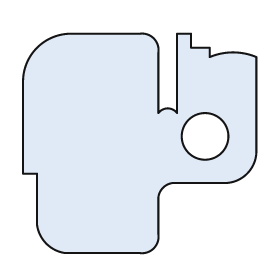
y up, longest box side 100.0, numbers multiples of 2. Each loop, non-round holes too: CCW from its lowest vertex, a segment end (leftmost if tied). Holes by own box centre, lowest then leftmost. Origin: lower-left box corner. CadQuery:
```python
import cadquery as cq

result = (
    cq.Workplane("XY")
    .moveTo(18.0, 0.0)
    .lineTo(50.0, 0.0)
    .threePointArc((56.0, 2.0), (58.0, 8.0))
    .lineTo(58.0, 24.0)
    .threePointArc((60.0, 28.0), (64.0, 30.0))
    .lineTo(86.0, 30.0)
    .threePointArc((96.0, 34.0), (100.0, 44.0))
    .lineTo(100.0, 84.0)
    .threePointArc((90.0, 86.0), (80.0, 84.0))
    .lineTo(80.0, 88.0)
    .lineTo(72.0, 88.0)
    .lineTo(72.0, 94.0)
    .lineTo(66.0, 94.0)
    .lineTo(66.0, 60.0)
    .threePointArc((62.0, 62.0), (58.0, 60.0))
    .lineTo(58.0, 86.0)
    .threePointArc((56.0, 92.0), (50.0, 94.0))
    .lineTo(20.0, 94.0)
    .threePointArc((6.0, 88.0), (0.0, 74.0))
    .lineTo(0.0, 34.0)
    .lineTo(6.0, 34.0)
    .lineTo(6.0, 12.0)
    .threePointArc((10.0, 4.0), (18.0, 0.0))
    .close()
    .moveTo(78.0, 50.0)
    .circle(10.0)
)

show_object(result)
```